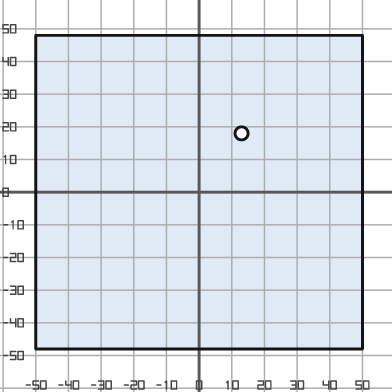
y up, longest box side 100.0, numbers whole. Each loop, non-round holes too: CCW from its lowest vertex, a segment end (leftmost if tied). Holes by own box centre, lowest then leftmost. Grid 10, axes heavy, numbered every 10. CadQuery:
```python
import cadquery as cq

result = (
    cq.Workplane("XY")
    .moveTo(-50.0, -48.0)
    .lineTo(50.0, -48.0)
    .lineTo(50.0, 48.0)
    .lineTo(-50.0, 48.0)
    .close()
    .moveTo(13.0, 18.0)
    .circle(2.0)
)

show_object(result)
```